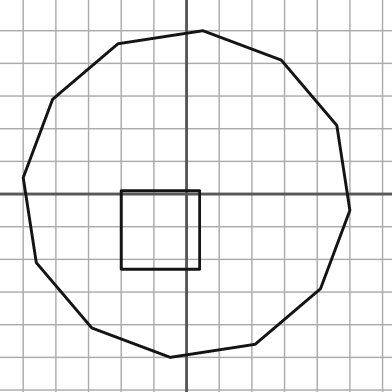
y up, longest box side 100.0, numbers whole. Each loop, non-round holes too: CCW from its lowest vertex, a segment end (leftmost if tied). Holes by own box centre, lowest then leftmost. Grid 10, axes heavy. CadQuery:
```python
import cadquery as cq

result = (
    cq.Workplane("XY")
    .moveTo(-5.0, -50.0)
    .lineTo(21.0, -46.0)
    .lineTo(41.0, -29.0)
    .lineTo(50.0, -5.0)
    .lineTo(46.0, 21.0)
    .lineTo(29.0, 41.0)
    .lineTo(5.0, 50.0)
    .lineTo(-21.0, 46.0)
    .lineTo(-41.0, 29.0)
    .lineTo(-50.0, 5.0)
    .lineTo(-46.0, -21.0)
    .lineTo(-29.0, -41.0)
    .close()
    .moveTo(-20.0, -23.0)
    .lineTo(4.0, -23.0)
    .lineTo(4.0, 1.0)
    .lineTo(-20.0, 1.0)
    .close()
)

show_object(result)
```